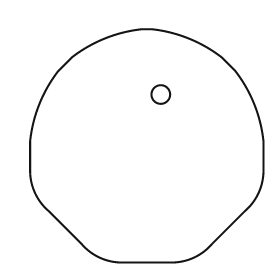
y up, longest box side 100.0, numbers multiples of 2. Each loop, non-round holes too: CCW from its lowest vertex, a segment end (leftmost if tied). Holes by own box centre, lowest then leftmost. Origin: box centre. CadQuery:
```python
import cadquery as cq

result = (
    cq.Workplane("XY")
    .moveTo(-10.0, -50.0)
    .lineTo(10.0, -50.0)
    .threePointArc((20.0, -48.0), (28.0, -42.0))
    .lineTo(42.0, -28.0)
    .threePointArc((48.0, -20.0), (50.0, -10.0))
    .lineTo(50.0, 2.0)
    .threePointArc((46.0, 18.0), (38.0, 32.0))
    .lineTo(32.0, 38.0)
    .threePointArc((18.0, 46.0), (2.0, 50.0))
    .lineTo(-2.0, 50.0)
    .threePointArc((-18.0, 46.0), (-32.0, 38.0))
    .lineTo(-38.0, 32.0)
    .threePointArc((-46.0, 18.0), (-50.0, 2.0))
    .lineTo(-50.0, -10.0)
    .threePointArc((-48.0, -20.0), (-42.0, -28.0))
    .lineTo(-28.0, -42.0)
    .threePointArc((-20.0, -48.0), (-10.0, -50.0))
    .close()
    .moveTo(6.0, 22.0)
    .circle(4.0)
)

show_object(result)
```